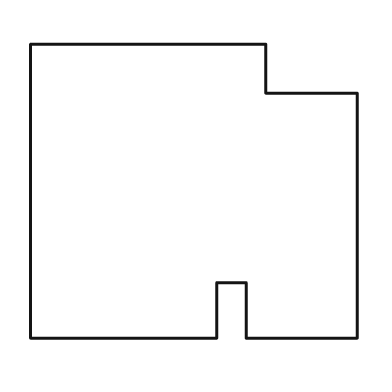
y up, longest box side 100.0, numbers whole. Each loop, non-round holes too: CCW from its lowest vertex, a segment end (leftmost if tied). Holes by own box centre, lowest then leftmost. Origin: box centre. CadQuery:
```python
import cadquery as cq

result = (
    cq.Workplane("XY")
    .moveTo(-50.0, -45.0)
    .lineTo(7.0, -45.0)
    .lineTo(7.0, -28.0)
    .lineTo(16.0, -28.0)
    .lineTo(16.0, -45.0)
    .lineTo(50.0, -45.0)
    .lineTo(50.0, 30.0)
    .lineTo(22.0, 30.0)
    .lineTo(22.0, 45.0)
    .lineTo(-50.0, 45.0)
    .close()
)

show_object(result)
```